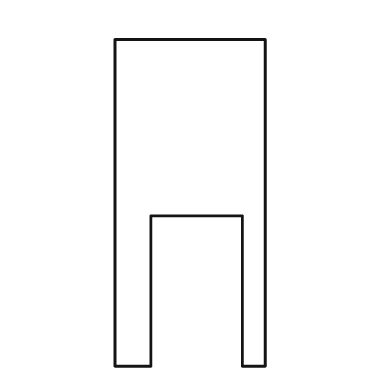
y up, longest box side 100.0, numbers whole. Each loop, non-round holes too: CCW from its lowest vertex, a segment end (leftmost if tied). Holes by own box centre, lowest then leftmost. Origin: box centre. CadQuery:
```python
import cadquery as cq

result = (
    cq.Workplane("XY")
    .moveTo(-23.0, -50.0)
    .lineTo(-12.0, -50.0)
    .lineTo(-12.0, -4.0)
    .lineTo(16.0, -4.0)
    .lineTo(16.0, -50.0)
    .lineTo(23.0, -50.0)
    .lineTo(23.0, 50.0)
    .lineTo(-23.0, 50.0)
    .close()
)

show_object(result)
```